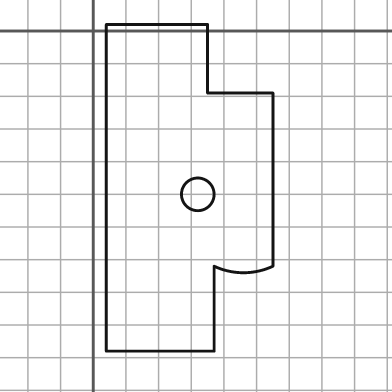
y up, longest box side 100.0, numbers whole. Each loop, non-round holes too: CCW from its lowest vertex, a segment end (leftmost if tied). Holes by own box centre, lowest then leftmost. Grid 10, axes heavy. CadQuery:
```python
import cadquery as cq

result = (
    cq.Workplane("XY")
    .moveTo(4.0, -98.0)
    .lineTo(37.0, -98.0)
    .lineTo(37.0, -72.0)
    .threePointArc((46.0, -74.0), (55.0, -72.0))
    .lineTo(55.0, -19.0)
    .lineTo(35.0, -19.0)
    .lineTo(35.0, 2.0)
    .lineTo(4.0, 2.0)
    .close()
    .moveTo(32.0, -50.0)
    .circle(5.0)
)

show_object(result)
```